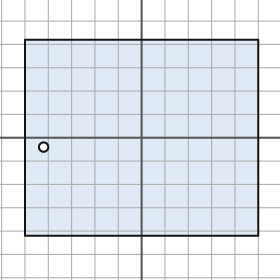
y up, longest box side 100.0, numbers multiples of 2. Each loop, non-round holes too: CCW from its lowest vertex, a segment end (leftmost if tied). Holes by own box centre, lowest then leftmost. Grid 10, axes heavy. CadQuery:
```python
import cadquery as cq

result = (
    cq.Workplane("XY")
    .moveTo(-50.0, -42.0)
    .lineTo(50.0, -42.0)
    .lineTo(50.0, 42.0)
    .lineTo(-50.0, 42.0)
    .close()
    .moveTo(-42.0, -4.0)
    .circle(2.0)
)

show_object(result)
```